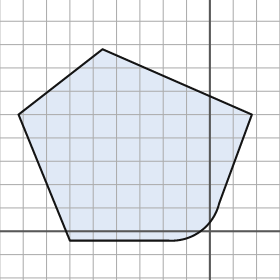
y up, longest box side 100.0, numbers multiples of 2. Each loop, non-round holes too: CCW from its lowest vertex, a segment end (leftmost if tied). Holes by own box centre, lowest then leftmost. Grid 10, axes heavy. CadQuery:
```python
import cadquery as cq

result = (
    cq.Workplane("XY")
    .moveTo(-60.0, -4.0)
    .lineTo(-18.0, -4.0)
    .threePointArc((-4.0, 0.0), (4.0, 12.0))
    .lineTo(18.0, 50.0)
    .lineTo(-46.0, 78.0)
    .lineTo(-82.0, 50.0)
    .close()
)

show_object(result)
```